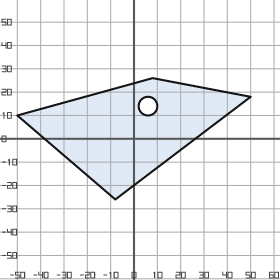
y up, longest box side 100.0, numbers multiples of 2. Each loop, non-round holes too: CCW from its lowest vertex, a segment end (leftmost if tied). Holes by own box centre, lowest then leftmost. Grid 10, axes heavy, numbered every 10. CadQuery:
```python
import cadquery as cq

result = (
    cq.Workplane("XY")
    .moveTo(-8.0, -26.0)
    .lineTo(50.0, 18.0)
    .lineTo(8.0, 26.0)
    .lineTo(-50.0, 10.0)
    .close()
    .moveTo(6.0, 14.0)
    .circle(4.0)
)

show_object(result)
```